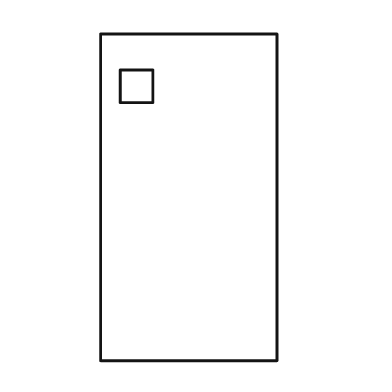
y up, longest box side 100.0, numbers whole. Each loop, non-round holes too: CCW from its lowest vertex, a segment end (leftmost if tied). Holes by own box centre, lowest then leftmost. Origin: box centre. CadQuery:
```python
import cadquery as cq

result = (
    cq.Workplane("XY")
    .moveTo(-27.0, -50.0)
    .lineTo(27.0, -50.0)
    .lineTo(27.0, 50.0)
    .lineTo(-27.0, 50.0)
    .close()
    .moveTo(-21.0, 29.0)
    .lineTo(-11.0, 29.0)
    .lineTo(-11.0, 39.0)
    .lineTo(-21.0, 39.0)
    .close()
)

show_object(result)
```